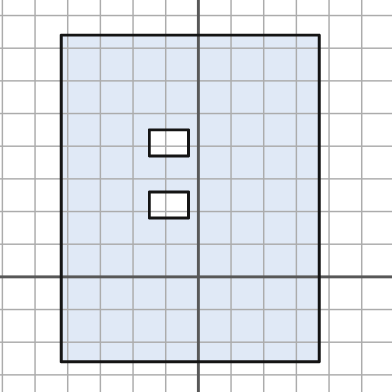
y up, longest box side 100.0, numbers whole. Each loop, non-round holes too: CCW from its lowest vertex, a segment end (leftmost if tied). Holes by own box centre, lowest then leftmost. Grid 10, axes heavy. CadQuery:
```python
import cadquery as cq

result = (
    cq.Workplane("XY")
    .moveTo(-42.0, -26.0)
    .lineTo(37.0, -26.0)
    .lineTo(37.0, 74.0)
    .lineTo(-42.0, 74.0)
    .close()
    .moveTo(-15.0, 18.0)
    .lineTo(-3.0, 18.0)
    .lineTo(-3.0, 26.0)
    .lineTo(-15.0, 26.0)
    .close()
    .moveTo(-15.0, 37.0)
    .lineTo(-3.0, 37.0)
    .lineTo(-3.0, 45.0)
    .lineTo(-15.0, 45.0)
    .close()
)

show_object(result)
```